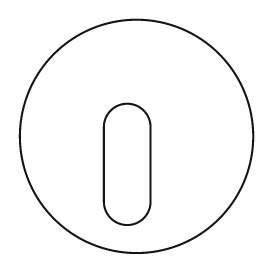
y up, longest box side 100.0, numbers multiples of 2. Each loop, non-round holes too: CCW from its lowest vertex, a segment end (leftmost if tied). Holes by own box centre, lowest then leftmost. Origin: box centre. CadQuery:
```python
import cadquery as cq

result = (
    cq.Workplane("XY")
    .moveTo(0.0, 0.0)
    .circle(50.0)
    .moveTo(-14.0, -28.0)
    .threePointArc((-4.0, -38.0), (6.0, -28.0))
    .lineTo(6.0, 4.0)
    .threePointArc((-4.0, 14.0), (-14.0, 4.0))
    .close()
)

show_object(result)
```